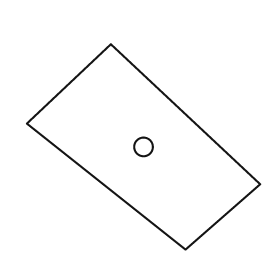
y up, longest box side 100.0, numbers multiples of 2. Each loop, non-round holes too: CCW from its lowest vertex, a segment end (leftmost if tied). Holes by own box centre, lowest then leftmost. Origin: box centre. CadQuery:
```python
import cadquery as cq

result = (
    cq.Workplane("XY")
    .moveTo(18.0, -44.0)
    .lineTo(50.0, -16.0)
    .lineTo(-14.0, 44.0)
    .lineTo(-50.0, 10.0)
    .close()
    .moveTo(0.0, 0.0)
    .circle(4.0)
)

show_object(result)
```